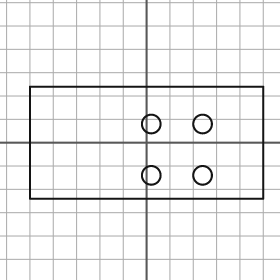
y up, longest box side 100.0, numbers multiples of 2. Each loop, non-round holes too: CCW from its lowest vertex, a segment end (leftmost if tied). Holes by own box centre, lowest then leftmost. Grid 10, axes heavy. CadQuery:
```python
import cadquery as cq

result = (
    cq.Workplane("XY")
    .moveTo(-50.0, -24.0)
    .lineTo(50.0, -24.0)
    .lineTo(50.0, 24.0)
    .lineTo(-50.0, 24.0)
    .close()
    .moveTo(2.0, -14.0)
    .circle(4.0)
    .moveTo(24.0, -14.0)
    .circle(4.0)
    .moveTo(2.0, 8.0)
    .circle(4.0)
    .moveTo(24.0, 8.0)
    .circle(4.0)
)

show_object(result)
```